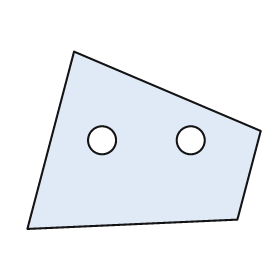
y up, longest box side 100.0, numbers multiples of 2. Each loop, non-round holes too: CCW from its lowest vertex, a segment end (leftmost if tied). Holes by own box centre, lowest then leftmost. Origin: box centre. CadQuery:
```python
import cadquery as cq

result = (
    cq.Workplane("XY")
    .moveTo(-50.0, -38.0)
    .lineTo(40.0, -34.0)
    .lineTo(50.0, 4.0)
    .lineTo(-30.0, 38.0)
    .close()
    .moveTo(-18.0, 0.0)
    .circle(6.0)
    .moveTo(20.0, 0.0)
    .circle(6.0)
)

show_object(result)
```